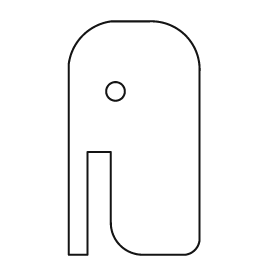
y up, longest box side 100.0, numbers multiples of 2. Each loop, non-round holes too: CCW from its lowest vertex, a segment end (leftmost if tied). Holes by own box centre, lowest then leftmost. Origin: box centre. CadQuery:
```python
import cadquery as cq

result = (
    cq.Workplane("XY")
    .moveTo(-28.0, -50.0)
    .lineTo(-20.0, -50.0)
    .lineTo(-20.0, -6.0)
    .lineTo(-10.0, -6.0)
    .lineTo(-10.0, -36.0)
    .threePointArc((-6.0, -46.0), (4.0, -50.0))
    .lineTo(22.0, -50.0)
    .threePointArc((26.0, -48.0), (28.0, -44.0))
    .lineTo(28.0, 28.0)
    .threePointArc((22.0, 44.0), (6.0, 50.0))
    .lineTo(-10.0, 50.0)
    .threePointArc((-22.0, 44.0), (-28.0, 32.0))
    .close()
    .moveTo(-8.0, 20.0)
    .circle(4.0)
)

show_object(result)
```